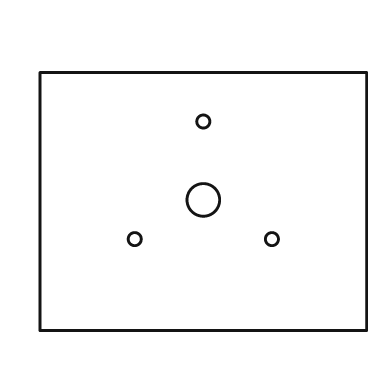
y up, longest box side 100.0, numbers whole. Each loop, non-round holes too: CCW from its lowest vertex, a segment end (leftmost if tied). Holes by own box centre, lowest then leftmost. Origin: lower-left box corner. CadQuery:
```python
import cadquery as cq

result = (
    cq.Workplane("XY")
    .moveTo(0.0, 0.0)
    .lineTo(100.0, 0.0)
    .lineTo(100.0, 79.0)
    .lineTo(0.0, 79.0)
    .close()
    .moveTo(29.0, 28.0)
    .circle(2.0)
    .moveTo(71.0, 28.0)
    .circle(2.0)
    .moveTo(50.0, 40.0)
    .circle(5.0)
    .moveTo(50.0, 64.0)
    .circle(2.0)
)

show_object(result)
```